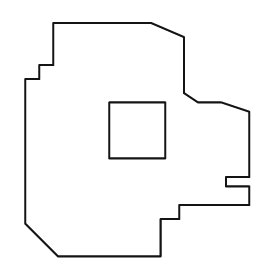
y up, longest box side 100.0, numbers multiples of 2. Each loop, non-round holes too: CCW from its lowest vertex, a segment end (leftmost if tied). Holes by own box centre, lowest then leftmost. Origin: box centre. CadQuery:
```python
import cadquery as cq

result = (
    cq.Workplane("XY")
    .moveTo(-34.0, -50.0)
    .lineTo(10.0, -50.0)
    .lineTo(10.0, -34.0)
    .lineTo(18.0, -34.0)
    .lineTo(18.0, -28.0)
    .lineTo(48.0, -28.0)
    .lineTo(48.0, -20.0)
    .lineTo(38.0, -20.0)
    .lineTo(38.0, -16.0)
    .lineTo(48.0, -16.0)
    .lineTo(48.0, 12.0)
    .lineTo(36.0, 16.0)
    .lineTo(26.0, 16.0)
    .lineTo(20.0, 20.0)
    .lineTo(20.0, 44.0)
    .lineTo(6.0, 50.0)
    .lineTo(-36.0, 50.0)
    .lineTo(-36.0, 32.0)
    .lineTo(-42.0, 32.0)
    .lineTo(-42.0, 26.0)
    .lineTo(-48.0, 26.0)
    .lineTo(-48.0, -36.0)
    .close()
    .moveTo(-12.0, -8.0)
    .lineTo(12.0, -8.0)
    .lineTo(12.0, 16.0)
    .lineTo(-12.0, 16.0)
    .close()
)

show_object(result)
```